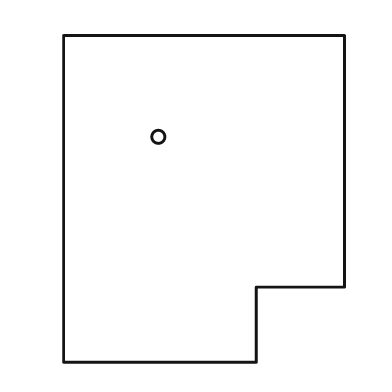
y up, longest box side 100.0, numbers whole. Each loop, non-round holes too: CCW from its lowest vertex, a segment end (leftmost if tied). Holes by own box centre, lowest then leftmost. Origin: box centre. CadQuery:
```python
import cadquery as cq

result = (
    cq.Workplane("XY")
    .moveTo(-43.0, -50.0)
    .lineTo(16.0, -50.0)
    .lineTo(16.0, -27.0)
    .lineTo(43.0, -27.0)
    .lineTo(43.0, 50.0)
    .lineTo(-43.0, 50.0)
    .close()
    .moveTo(-14.0, 19.0)
    .circle(2.0)
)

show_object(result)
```